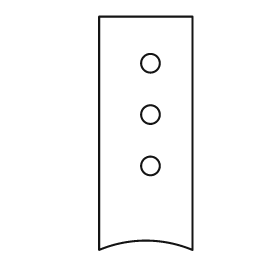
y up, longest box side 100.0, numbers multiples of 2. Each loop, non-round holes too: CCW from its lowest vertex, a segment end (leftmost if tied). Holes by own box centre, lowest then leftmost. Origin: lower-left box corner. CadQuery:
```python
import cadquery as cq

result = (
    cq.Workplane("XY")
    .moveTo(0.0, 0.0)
    .threePointArc((20.0, 4.0), (40.0, 0.0))
    .lineTo(40.0, 100.0)
    .lineTo(0.0, 100.0)
    .close()
    .moveTo(22.0, 36.0)
    .circle(4.0)
    .moveTo(22.0, 58.0)
    .circle(4.0)
    .moveTo(22.0, 80.0)
    .circle(4.0)
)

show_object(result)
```